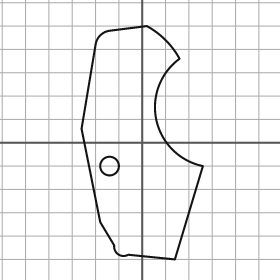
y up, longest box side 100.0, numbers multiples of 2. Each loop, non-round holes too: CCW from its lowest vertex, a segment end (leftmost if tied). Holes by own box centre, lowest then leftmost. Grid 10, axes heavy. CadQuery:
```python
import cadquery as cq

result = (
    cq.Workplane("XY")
    .moveTo(14.0, -50.0)
    .lineTo(26.0, -10.0)
    .threePointArc((6.0, 10.0), (16.0, 36.0))
    .threePointArc((10.0, 44.0), (2.0, 50.0))
    .lineTo(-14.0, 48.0)
    .threePointArc((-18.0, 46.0), (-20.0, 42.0))
    .lineTo(-26.0, 6.0)
    .lineTo(-18.0, -34.0)
    .lineTo(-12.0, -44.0)
    .threePointArc((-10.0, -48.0), (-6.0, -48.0))
    .close()
    .moveTo(-14.0, -10.0)
    .circle(4.0)
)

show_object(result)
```